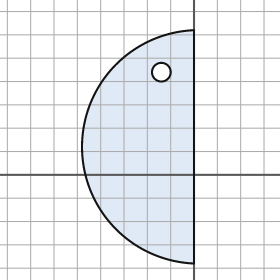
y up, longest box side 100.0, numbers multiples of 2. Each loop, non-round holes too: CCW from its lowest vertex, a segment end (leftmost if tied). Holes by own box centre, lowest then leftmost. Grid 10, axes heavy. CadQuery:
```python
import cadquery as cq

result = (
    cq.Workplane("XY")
    .moveTo(0.0, -38.0)
    .lineTo(0.0, 62.0)
    .threePointArc((-48.0, 12.0), (0.0, -38.0))
    .close()
    .moveTo(-14.0, 44.0)
    .circle(4.0)
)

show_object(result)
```